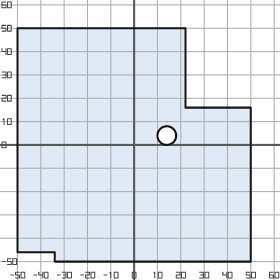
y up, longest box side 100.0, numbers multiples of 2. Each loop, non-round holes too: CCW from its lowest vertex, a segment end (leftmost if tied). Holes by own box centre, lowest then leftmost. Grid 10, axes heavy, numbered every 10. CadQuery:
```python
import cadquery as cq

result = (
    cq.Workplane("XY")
    .moveTo(-34.0, -50.0)
    .lineTo(50.0, -50.0)
    .lineTo(50.0, 16.0)
    .lineTo(22.0, 16.0)
    .lineTo(22.0, 50.0)
    .lineTo(-50.0, 50.0)
    .lineTo(-50.0, -46.0)
    .lineTo(-34.0, -46.0)
    .close()
    .moveTo(14.0, 4.0)
    .circle(4.0)
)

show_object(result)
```